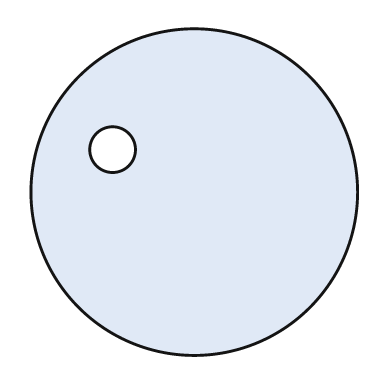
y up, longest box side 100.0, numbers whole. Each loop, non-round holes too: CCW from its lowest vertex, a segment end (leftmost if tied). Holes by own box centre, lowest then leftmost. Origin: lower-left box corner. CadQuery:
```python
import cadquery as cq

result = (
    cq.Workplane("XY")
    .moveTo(50.0, 50.0)
    .circle(50.0)
    .moveTo(25.0, 63.0)
    .circle(7.0)
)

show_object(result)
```